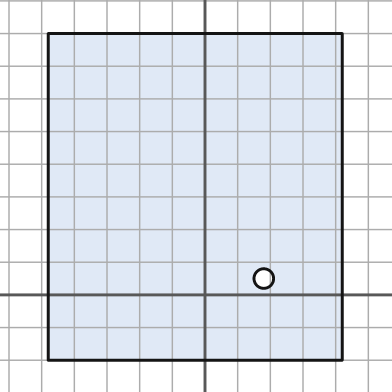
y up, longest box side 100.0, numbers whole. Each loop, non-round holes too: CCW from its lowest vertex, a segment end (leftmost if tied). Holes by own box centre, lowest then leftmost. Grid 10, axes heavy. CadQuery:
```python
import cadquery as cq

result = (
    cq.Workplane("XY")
    .moveTo(-48.0, -20.0)
    .lineTo(42.0, -20.0)
    .lineTo(42.0, 80.0)
    .lineTo(-48.0, 80.0)
    .close()
    .moveTo(18.0, 5.0)
    .circle(3.0)
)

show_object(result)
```